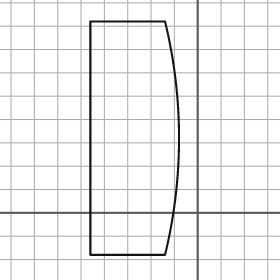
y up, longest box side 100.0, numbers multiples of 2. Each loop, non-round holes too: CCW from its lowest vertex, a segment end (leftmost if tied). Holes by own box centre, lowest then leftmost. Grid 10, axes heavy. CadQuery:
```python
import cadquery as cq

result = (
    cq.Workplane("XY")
    .moveTo(-46.0, -18.0)
    .lineTo(-14.0, -18.0)
    .threePointArc((-8.0, 32.0), (-14.0, 82.0))
    .lineTo(-46.0, 82.0)
    .close()
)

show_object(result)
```